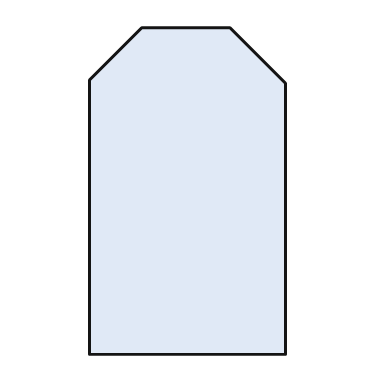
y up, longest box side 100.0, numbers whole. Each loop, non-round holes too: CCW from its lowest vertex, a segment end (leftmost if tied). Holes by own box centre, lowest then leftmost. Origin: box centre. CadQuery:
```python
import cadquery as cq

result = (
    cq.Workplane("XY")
    .moveTo(-30.0, -50.0)
    .lineTo(30.0, -50.0)
    .lineTo(30.0, 33.0)
    .lineTo(13.0, 50.0)
    .lineTo(-14.0, 50.0)
    .lineTo(-30.0, 34.0)
    .close()
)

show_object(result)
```